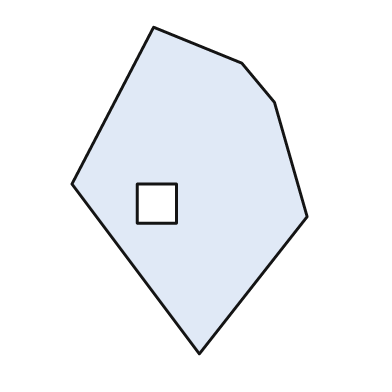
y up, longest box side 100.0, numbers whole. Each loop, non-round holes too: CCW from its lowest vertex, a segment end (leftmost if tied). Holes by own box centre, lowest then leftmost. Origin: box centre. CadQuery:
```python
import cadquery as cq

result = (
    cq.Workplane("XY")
    .moveTo(3.0, -50.0)
    .lineTo(36.0, -8.0)
    .lineTo(26.0, 27.0)
    .lineTo(16.0, 39.0)
    .lineTo(-11.0, 50.0)
    .lineTo(-36.0, 2.0)
    .close()
    .moveTo(-16.0, -10.0)
    .lineTo(-4.0, -10.0)
    .lineTo(-4.0, 2.0)
    .lineTo(-16.0, 2.0)
    .close()
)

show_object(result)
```